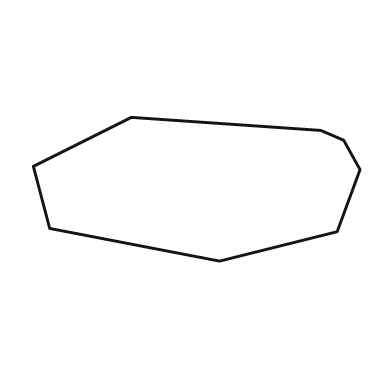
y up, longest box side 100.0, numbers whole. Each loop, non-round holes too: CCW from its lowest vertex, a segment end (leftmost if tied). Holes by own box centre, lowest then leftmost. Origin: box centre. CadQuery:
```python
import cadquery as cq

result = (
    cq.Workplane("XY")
    .moveTo(7.0, -22.0)
    .lineTo(43.0, -13.0)
    .lineTo(50.0, 6.0)
    .lineTo(45.0, 15.0)
    .lineTo(38.0, 18.0)
    .lineTo(-20.0, 22.0)
    .lineTo(-50.0, 7.0)
    .lineTo(-45.0, -12.0)
    .close()
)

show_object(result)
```